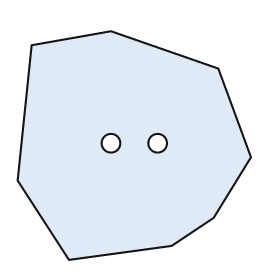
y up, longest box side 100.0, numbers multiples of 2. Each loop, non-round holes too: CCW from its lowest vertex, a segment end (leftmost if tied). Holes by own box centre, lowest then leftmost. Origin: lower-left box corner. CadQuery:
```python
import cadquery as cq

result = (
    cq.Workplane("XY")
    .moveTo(22.0, 0.0)
    .lineTo(66.0, 6.0)
    .lineTo(84.0, 18.0)
    .lineTo(100.0, 44.0)
    .lineTo(86.0, 82.0)
    .lineTo(40.0, 98.0)
    .lineTo(6.0, 92.0)
    .lineTo(0.0, 34.0)
    .close()
    .moveTo(40.0, 50.0)
    .circle(4.0)
    .moveTo(60.0, 50.0)
    .circle(4.0)
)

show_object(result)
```